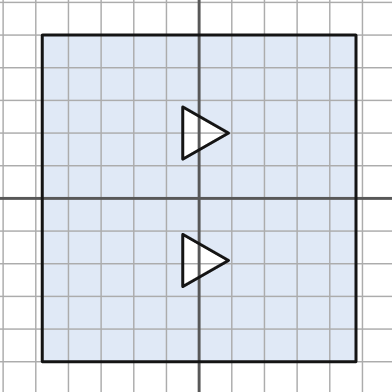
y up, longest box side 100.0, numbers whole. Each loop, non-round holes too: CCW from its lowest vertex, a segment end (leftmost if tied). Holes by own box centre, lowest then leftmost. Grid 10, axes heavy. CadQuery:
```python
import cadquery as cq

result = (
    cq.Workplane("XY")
    .moveTo(-48.0, -50.0)
    .lineTo(48.0, -50.0)
    .lineTo(48.0, 50.0)
    .lineTo(-48.0, 50.0)
    .close()
    .moveTo(-5.0, -27.0)
    .lineTo(9.0, -19.0)
    .lineTo(-5.0, -11.0)
    .close()
    .moveTo(-5.0, 12.0)
    .lineTo(9.0, 20.0)
    .lineTo(-5.0, 28.0)
    .close()
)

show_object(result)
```